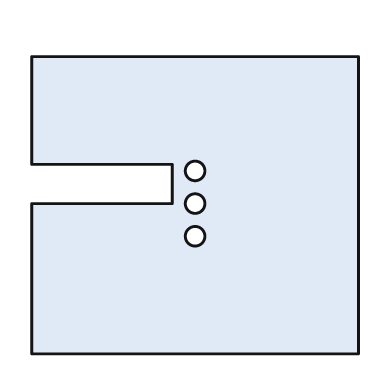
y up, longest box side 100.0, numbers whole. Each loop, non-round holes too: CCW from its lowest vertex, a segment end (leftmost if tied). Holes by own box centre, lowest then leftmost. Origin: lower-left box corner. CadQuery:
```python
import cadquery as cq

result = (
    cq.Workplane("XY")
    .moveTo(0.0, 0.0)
    .lineTo(100.0, 0.0)
    .lineTo(100.0, 91.0)
    .lineTo(0.0, 91.0)
    .lineTo(0.0, 58.0)
    .lineTo(43.0, 58.0)
    .lineTo(43.0, 46.0)
    .lineTo(0.0, 46.0)
    .close()
    .moveTo(50.0, 36.0)
    .circle(3.0)
    .moveTo(50.0, 46.0)
    .circle(3.0)
    .moveTo(50.0, 56.0)
    .circle(3.0)
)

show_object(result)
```